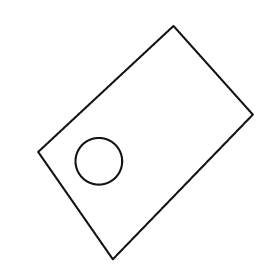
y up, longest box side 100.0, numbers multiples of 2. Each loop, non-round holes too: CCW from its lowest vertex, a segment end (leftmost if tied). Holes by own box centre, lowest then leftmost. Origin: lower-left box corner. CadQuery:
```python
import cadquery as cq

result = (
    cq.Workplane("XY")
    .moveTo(32.0, 0.0)
    .lineTo(92.0, 62.0)
    .lineTo(58.0, 100.0)
    .lineTo(0.0, 46.0)
    .close()
    .moveTo(26.0, 42.0)
    .circle(10.0)
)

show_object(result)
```